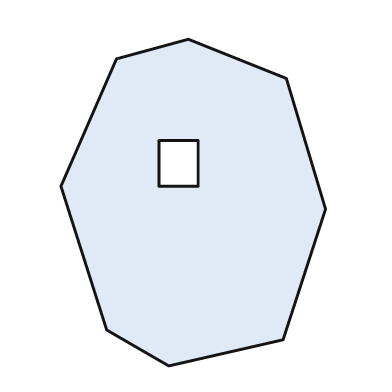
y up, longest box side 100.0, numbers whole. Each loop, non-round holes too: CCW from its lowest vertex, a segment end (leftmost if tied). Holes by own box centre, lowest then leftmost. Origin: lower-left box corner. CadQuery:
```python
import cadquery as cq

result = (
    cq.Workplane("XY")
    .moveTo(33.0, 0.0)
    .lineTo(68.0, 8.0)
    .lineTo(81.0, 48.0)
    .lineTo(69.0, 88.0)
    .lineTo(39.0, 100.0)
    .lineTo(17.0, 94.0)
    .lineTo(0.0, 55.0)
    .lineTo(14.0, 11.0)
    .close()
    .moveTo(30.0, 55.0)
    .lineTo(42.0, 55.0)
    .lineTo(42.0, 69.0)
    .lineTo(30.0, 69.0)
    .close()
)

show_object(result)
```